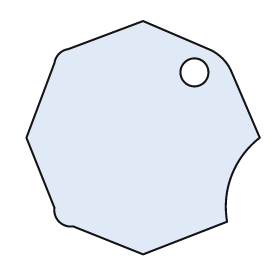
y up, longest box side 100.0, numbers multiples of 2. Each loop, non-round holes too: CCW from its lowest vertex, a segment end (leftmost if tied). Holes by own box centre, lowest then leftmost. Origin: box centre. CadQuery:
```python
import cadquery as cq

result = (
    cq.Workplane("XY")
    .moveTo(0.0, -50.0)
    .lineTo(36.0, -36.0)
    .threePointArc((38.0, -16.0), (50.0, 0.0))
    .lineTo(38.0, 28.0)
    .threePointArc((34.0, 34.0), (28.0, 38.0))
    .lineTo(0.0, 50.0)
    .lineTo(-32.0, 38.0)
    .threePointArc((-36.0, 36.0), (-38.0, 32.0))
    .lineTo(-50.0, 0.0)
    .lineTo(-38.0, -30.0)
    .threePointArc((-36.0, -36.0), (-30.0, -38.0))
    .close()
    .moveTo(22.0, 28.0)
    .circle(6.0)
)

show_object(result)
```